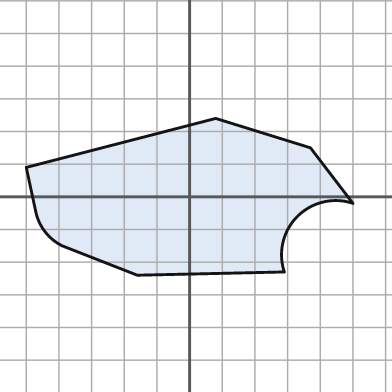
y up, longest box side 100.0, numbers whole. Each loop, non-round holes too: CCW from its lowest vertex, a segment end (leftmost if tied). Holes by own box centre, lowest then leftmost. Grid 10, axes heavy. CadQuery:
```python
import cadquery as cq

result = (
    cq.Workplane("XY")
    .moveTo(-16.0, -24.0)
    .lineTo(29.0, -23.0)
    .threePointArc((33.0, -6.0), (50.0, -2.0))
    .lineTo(37.0, 15.0)
    .lineTo(8.0, 24.0)
    .lineTo(-50.0, 9.0)
    .lineTo(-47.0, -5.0)
    .threePointArc((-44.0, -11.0), (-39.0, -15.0))
    .close()
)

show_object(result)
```